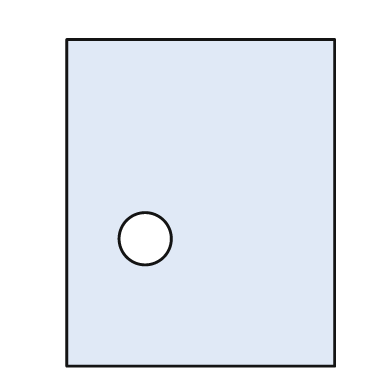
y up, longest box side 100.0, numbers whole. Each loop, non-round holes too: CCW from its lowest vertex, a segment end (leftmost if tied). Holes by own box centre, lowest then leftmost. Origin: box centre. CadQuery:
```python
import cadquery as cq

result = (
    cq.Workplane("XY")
    .moveTo(-41.0, -50.0)
    .lineTo(41.0, -50.0)
    .lineTo(41.0, 50.0)
    .lineTo(-41.0, 50.0)
    .close()
    .moveTo(-17.0, -11.0)
    .circle(8.0)
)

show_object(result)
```